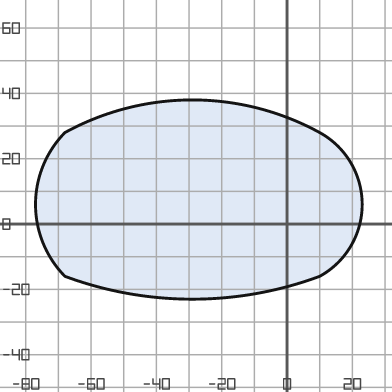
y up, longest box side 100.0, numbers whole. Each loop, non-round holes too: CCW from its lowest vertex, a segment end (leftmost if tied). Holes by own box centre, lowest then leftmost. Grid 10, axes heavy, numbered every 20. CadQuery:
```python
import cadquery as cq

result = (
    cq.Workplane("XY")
    .moveTo(-68.0, -16.0)
    .threePointArc((-29.0, -23.0), (10.0, -16.0))
    .threePointArc((23.0, 6.0), (10.0, 28.0))
    .threePointArc((-29.0, 38.0), (-68.0, 28.0))
    .threePointArc((-77.0, 6.0), (-68.0, -16.0))
    .close()
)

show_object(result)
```